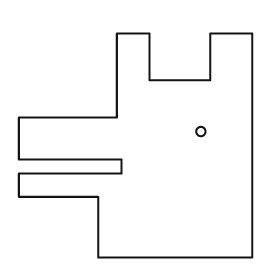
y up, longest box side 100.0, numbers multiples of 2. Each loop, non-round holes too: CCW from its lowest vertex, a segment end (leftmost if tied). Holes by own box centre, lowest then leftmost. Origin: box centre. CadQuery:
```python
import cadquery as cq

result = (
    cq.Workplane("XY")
    .moveTo(-16.0, -48.0)
    .lineTo(50.0, -48.0)
    .lineTo(50.0, 48.0)
    .lineTo(32.0, 48.0)
    .lineTo(32.0, 28.0)
    .lineTo(6.0, 28.0)
    .lineTo(6.0, 48.0)
    .lineTo(-8.0, 48.0)
    .lineTo(-8.0, 12.0)
    .lineTo(-50.0, 12.0)
    .lineTo(-50.0, -6.0)
    .lineTo(-6.0, -6.0)
    .lineTo(-6.0, -12.0)
    .lineTo(-50.0, -12.0)
    .lineTo(-50.0, -22.0)
    .lineTo(-16.0, -22.0)
    .close()
    .moveTo(28.0, 6.0)
    .circle(2.0)
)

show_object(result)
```